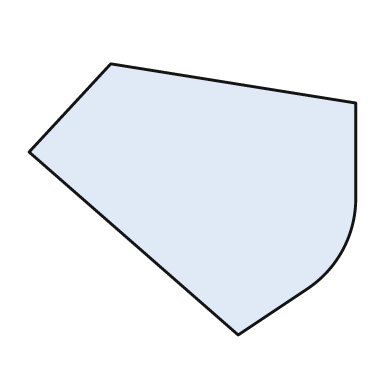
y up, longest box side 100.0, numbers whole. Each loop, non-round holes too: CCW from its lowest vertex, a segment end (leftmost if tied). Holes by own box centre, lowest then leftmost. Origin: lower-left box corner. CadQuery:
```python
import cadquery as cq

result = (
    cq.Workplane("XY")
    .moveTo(64.0, 0.0)
    .lineTo(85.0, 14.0)
    .threePointArc((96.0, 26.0), (100.0, 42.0))
    .lineTo(100.0, 71.0)
    .lineTo(25.0, 83.0)
    .lineTo(0.0, 56.0)
    .close()
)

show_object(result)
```